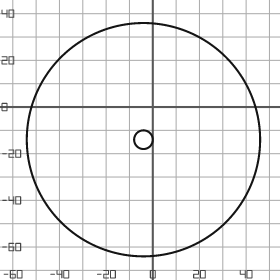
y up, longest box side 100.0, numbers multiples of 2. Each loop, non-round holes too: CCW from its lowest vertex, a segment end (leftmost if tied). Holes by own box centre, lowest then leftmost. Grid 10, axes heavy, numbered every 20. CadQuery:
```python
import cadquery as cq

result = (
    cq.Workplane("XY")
    .moveTo(-4.0, -14.0)
    .circle(50.0)
    .moveTo(-4.0, -14.0)
    .circle(4.0)
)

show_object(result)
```